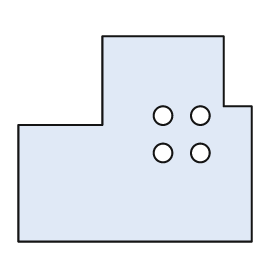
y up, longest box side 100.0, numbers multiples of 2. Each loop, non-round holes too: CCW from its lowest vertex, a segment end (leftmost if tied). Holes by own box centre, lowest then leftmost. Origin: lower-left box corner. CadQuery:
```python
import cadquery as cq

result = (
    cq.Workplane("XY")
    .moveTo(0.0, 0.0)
    .lineTo(100.0, 0.0)
    .lineTo(100.0, 58.0)
    .lineTo(88.0, 58.0)
    .lineTo(88.0, 88.0)
    .lineTo(36.0, 88.0)
    .lineTo(36.0, 50.0)
    .lineTo(0.0, 50.0)
    .close()
    .moveTo(62.0, 38.0)
    .circle(4.0)
    .moveTo(78.0, 38.0)
    .circle(4.0)
    .moveTo(62.0, 54.0)
    .circle(4.0)
    .moveTo(78.0, 54.0)
    .circle(4.0)
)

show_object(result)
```